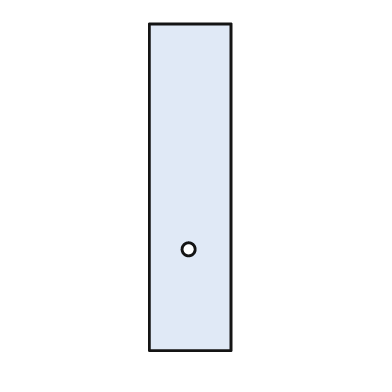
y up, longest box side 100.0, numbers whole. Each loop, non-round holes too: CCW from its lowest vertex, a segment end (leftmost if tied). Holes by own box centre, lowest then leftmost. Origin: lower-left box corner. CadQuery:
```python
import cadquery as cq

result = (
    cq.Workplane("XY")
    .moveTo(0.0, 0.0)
    .lineTo(25.0, 0.0)
    .lineTo(25.0, 100.0)
    .lineTo(0.0, 100.0)
    .close()
    .moveTo(12.0, 31.0)
    .circle(2.0)
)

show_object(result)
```